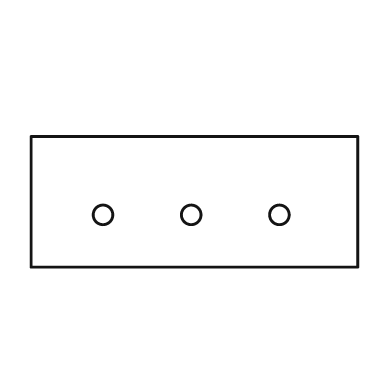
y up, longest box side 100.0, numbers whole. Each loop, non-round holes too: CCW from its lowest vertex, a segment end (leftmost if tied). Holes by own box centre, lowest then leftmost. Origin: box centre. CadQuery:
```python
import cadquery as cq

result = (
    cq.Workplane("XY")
    .moveTo(-50.0, -20.0)
    .lineTo(50.0, -20.0)
    .lineTo(50.0, 20.0)
    .lineTo(-50.0, 20.0)
    .close()
    .moveTo(-28.0, -4.0)
    .circle(3.0)
    .moveTo(-1.0, -4.0)
    .circle(3.0)
    .moveTo(26.0, -4.0)
    .circle(3.0)
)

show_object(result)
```